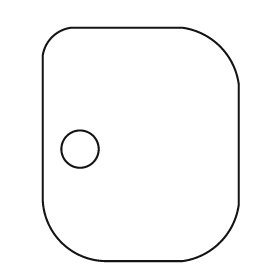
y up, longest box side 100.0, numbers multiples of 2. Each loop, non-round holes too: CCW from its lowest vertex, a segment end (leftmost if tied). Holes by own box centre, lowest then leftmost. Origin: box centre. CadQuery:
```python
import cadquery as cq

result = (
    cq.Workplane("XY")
    .moveTo(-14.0, -50.0)
    .lineTo(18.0, -50.0)
    .threePointArc((34.0, -42.0), (42.0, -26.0))
    .lineTo(42.0, 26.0)
    .threePointArc((34.0, 42.0), (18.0, 50.0))
    .lineTo(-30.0, 50.0)
    .threePointArc((-38.0, 46.0), (-42.0, 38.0))
    .lineTo(-42.0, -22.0)
    .threePointArc((-34.0, -42.0), (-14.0, -50.0))
    .close()
    .moveTo(-26.0, -2.0)
    .circle(8.0)
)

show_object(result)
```